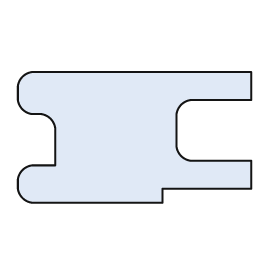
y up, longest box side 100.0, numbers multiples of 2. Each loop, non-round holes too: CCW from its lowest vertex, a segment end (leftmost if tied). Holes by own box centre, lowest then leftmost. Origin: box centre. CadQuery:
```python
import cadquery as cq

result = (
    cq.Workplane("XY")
    .moveTo(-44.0, -28.0)
    .lineTo(12.0, -28.0)
    .lineTo(12.0, -22.0)
    .lineTo(50.0, -22.0)
    .lineTo(50.0, -10.0)
    .lineTo(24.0, -10.0)
    .threePointArc((20.0, -8.0), (18.0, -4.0))
    .lineTo(18.0, 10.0)
    .threePointArc((20.0, 14.0), (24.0, 16.0))
    .lineTo(50.0, 16.0)
    .lineTo(50.0, 28.0)
    .lineTo(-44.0, 28.0)
    .threePointArc((-48.0, 26.0), (-50.0, 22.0))
    .lineTo(-50.0, 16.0)
    .threePointArc((-48.0, 12.0), (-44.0, 10.0))
    .lineTo(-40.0, 10.0)
    .threePointArc((-36.0, 8.0), (-34.0, 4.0))
    .lineTo(-34.0, -12.0)
    .lineTo(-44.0, -12.0)
    .threePointArc((-48.0, -14.0), (-50.0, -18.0))
    .lineTo(-50.0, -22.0)
    .threePointArc((-48.0, -26.0), (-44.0, -28.0))
    .close()
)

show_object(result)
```